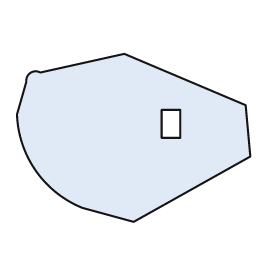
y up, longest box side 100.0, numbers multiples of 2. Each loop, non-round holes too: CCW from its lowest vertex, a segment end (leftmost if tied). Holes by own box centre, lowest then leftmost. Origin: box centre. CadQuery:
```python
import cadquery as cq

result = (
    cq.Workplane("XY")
    .moveTo(0.0, -36.0)
    .lineTo(50.0, -8.0)
    .lineTo(48.0, 14.0)
    .lineTo(-4.0, 36.0)
    .lineTo(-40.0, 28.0)
    .threePointArc((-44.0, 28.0), (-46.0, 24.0))
    .lineTo(-50.0, 10.0)
    .threePointArc((-42.0, -14.0), (-22.0, -30.0))
    .close()
    .moveTo(12.0, 0.0)
    .lineTo(20.0, 0.0)
    .lineTo(20.0, 12.0)
    .lineTo(12.0, 12.0)
    .close()
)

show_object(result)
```